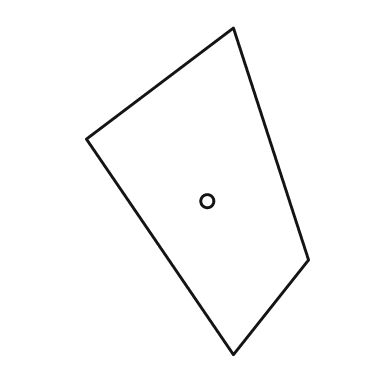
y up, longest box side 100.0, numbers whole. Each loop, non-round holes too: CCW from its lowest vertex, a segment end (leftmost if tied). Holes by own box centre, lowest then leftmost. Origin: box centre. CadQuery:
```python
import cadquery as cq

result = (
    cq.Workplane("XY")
    .moveTo(11.0, -50.0)
    .lineTo(34.0, -21.0)
    .lineTo(11.0, 50.0)
    .lineTo(-34.0, 16.0)
    .close()
    .moveTo(3.0, -3.0)
    .circle(2.0)
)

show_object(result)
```